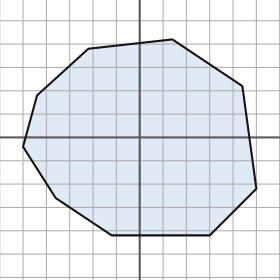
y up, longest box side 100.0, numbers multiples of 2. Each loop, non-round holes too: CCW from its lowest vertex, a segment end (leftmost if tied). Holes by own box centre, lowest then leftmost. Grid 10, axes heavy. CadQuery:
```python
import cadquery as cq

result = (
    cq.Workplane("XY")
    .moveTo(-12.0, -42.0)
    .lineTo(30.0, -42.0)
    .lineTo(50.0, -22.0)
    .lineTo(44.0, 22.0)
    .lineTo(14.0, 42.0)
    .lineTo(-22.0, 38.0)
    .lineTo(-44.0, 18.0)
    .lineTo(-50.0, -4.0)
    .lineTo(-36.0, -26.0)
    .close()
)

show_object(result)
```